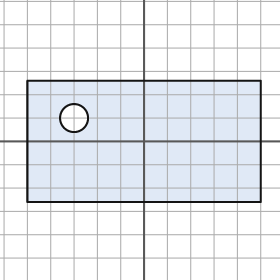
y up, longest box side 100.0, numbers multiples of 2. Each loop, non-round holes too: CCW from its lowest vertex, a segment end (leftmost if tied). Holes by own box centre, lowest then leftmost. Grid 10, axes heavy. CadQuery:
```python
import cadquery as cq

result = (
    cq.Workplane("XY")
    .moveTo(-50.0, -26.0)
    .lineTo(50.0, -26.0)
    .lineTo(50.0, 26.0)
    .lineTo(-50.0, 26.0)
    .close()
    .moveTo(-30.0, 10.0)
    .circle(6.0)
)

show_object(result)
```